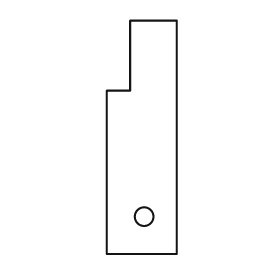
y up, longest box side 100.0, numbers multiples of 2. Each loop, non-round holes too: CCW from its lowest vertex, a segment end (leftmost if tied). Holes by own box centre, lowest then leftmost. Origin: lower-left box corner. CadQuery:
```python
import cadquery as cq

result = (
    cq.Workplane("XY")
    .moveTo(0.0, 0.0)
    .lineTo(30.0, 0.0)
    .lineTo(30.0, 100.0)
    .lineTo(10.0, 100.0)
    .lineTo(10.0, 70.0)
    .lineTo(0.0, 70.0)
    .close()
    .moveTo(16.0, 16.0)
    .circle(4.0)
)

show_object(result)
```